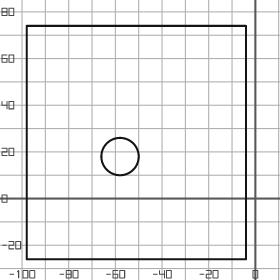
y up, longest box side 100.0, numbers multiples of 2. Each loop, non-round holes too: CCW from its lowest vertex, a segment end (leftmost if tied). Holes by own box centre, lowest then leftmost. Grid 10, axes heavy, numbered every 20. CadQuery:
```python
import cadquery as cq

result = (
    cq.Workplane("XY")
    .moveTo(-98.0, -26.0)
    .lineTo(-4.0, -26.0)
    .lineTo(-4.0, 74.0)
    .lineTo(-98.0, 74.0)
    .close()
    .moveTo(-58.0, 18.0)
    .circle(8.0)
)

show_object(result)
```